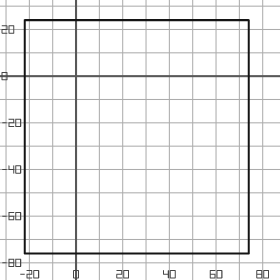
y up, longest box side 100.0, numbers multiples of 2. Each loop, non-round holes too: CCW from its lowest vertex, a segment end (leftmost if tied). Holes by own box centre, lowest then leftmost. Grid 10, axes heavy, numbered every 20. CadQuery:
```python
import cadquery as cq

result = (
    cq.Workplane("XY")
    .moveTo(-22.0, -76.0)
    .lineTo(74.0, -76.0)
    .lineTo(74.0, 24.0)
    .lineTo(-22.0, 24.0)
    .close()
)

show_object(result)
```